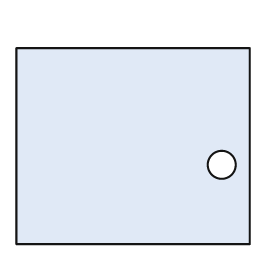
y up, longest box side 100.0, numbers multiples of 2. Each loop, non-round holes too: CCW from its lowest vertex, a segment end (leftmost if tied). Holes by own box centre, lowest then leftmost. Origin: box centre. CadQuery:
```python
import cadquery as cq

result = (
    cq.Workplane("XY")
    .moveTo(-50.0, -42.0)
    .lineTo(50.0, -42.0)
    .lineTo(50.0, 42.0)
    .lineTo(-50.0, 42.0)
    .close()
    .moveTo(38.0, -8.0)
    .circle(6.0)
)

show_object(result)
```